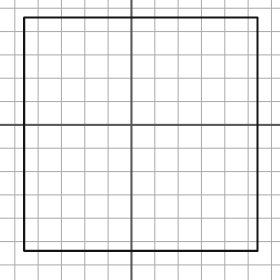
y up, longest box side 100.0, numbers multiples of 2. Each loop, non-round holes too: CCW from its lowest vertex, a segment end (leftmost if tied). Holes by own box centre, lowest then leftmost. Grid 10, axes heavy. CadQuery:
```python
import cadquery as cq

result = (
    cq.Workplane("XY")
    .moveTo(-46.0, -54.0)
    .lineTo(54.0, -54.0)
    .lineTo(54.0, 46.0)
    .lineTo(-46.0, 46.0)
    .close()
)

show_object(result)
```